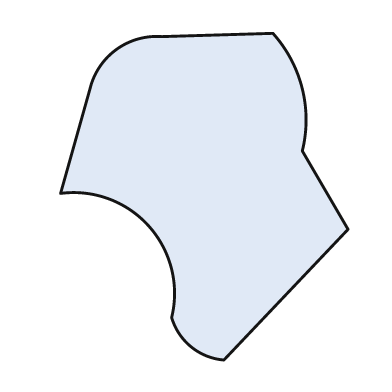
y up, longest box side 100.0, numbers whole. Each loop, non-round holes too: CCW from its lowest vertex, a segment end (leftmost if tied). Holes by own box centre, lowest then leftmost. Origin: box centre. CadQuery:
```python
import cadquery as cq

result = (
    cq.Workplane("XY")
    .moveTo(6.0, -50.0)
    .lineTo(44.0, -10.0)
    .lineTo(30.0, 14.0)
    .threePointArc((30.0, 33.0), (21.0, 50.0))
    .lineTo(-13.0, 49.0)
    .threePointArc((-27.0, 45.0), (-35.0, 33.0))
    .lineTo(-44.0, 1.0)
    .threePointArc((-17.0, -9.0), (-10.0, -37.0))
    .threePointArc((-4.0, -46.0), (6.0, -50.0))
    .close()
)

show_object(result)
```